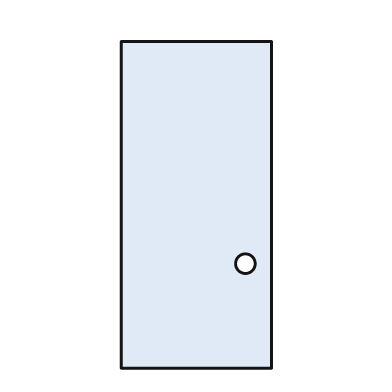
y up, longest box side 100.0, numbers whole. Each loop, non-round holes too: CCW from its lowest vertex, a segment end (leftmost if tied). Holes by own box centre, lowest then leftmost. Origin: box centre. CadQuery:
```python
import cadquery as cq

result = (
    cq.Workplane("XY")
    .moveTo(-23.0, -50.0)
    .lineTo(23.0, -50.0)
    .lineTo(23.0, 50.0)
    .lineTo(-23.0, 50.0)
    .close()
    .moveTo(15.0, -18.0)
    .circle(3.0)
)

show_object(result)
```